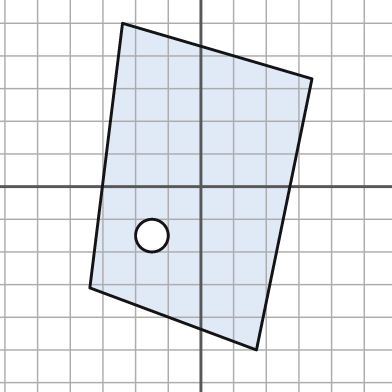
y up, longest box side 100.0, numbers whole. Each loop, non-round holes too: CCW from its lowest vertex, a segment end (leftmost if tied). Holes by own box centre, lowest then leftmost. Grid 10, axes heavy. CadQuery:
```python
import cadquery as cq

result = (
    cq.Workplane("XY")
    .moveTo(17.0, -50.0)
    .lineTo(34.0, 33.0)
    .lineTo(-24.0, 50.0)
    .lineTo(-34.0, -31.0)
    .close()
    .moveTo(-15.0, -15.0)
    .circle(5.0)
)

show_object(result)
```